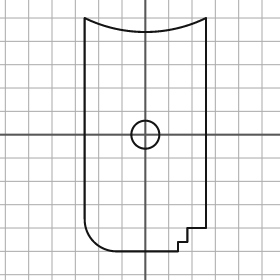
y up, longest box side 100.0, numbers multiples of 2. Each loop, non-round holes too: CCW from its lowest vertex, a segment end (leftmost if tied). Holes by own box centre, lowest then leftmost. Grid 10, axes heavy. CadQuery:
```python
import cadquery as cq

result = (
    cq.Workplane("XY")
    .moveTo(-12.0, -50.0)
    .lineTo(14.0, -50.0)
    .lineTo(14.0, -46.0)
    .lineTo(18.0, -46.0)
    .lineTo(18.0, -40.0)
    .lineTo(26.0, -40.0)
    .lineTo(26.0, 50.0)
    .threePointArc((0.0, 44.0), (-26.0, 50.0))
    .lineTo(-26.0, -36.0)
    .threePointArc((-22.0, -46.0), (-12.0, -50.0))
    .close()
    .moveTo(0.0, 0.0)
    .circle(6.0)
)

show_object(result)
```